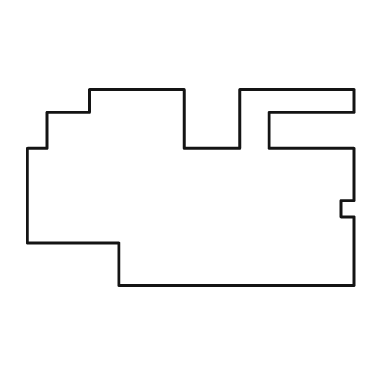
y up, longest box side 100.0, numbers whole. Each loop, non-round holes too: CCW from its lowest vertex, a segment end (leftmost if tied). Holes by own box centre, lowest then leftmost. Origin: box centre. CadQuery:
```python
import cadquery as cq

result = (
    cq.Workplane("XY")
    .moveTo(-22.0, -30.0)
    .lineTo(50.0, -30.0)
    .lineTo(50.0, -9.0)
    .lineTo(46.0, -9.0)
    .lineTo(46.0, -4.0)
    .lineTo(50.0, -4.0)
    .lineTo(50.0, 12.0)
    .lineTo(24.0, 12.0)
    .lineTo(24.0, 23.0)
    .lineTo(50.0, 23.0)
    .lineTo(50.0, 30.0)
    .lineTo(15.0, 30.0)
    .lineTo(15.0, 12.0)
    .lineTo(-2.0, 12.0)
    .lineTo(-2.0, 30.0)
    .lineTo(-31.0, 30.0)
    .lineTo(-31.0, 23.0)
    .lineTo(-44.0, 23.0)
    .lineTo(-44.0, 12.0)
    .lineTo(-50.0, 12.0)
    .lineTo(-50.0, -17.0)
    .lineTo(-22.0, -17.0)
    .close()
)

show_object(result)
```